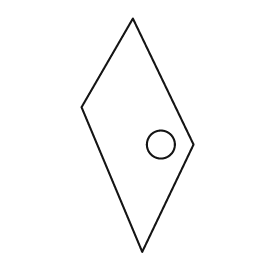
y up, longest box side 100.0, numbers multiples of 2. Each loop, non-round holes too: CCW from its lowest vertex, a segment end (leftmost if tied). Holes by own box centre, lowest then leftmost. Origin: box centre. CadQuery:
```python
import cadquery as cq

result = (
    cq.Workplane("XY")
    .moveTo(2.0, -50.0)
    .lineTo(24.0, -4.0)
    .lineTo(-2.0, 50.0)
    .lineTo(-24.0, 12.0)
    .close()
    .moveTo(10.0, -4.0)
    .circle(6.0)
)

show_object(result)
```